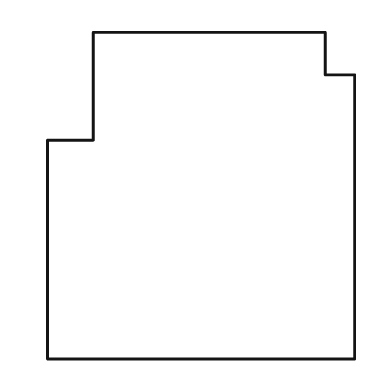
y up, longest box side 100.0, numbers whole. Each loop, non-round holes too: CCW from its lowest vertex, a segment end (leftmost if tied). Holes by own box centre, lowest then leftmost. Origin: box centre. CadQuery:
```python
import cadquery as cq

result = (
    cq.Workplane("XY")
    .moveTo(-47.0, -50.0)
    .lineTo(47.0, -50.0)
    .lineTo(47.0, 37.0)
    .lineTo(38.0, 37.0)
    .lineTo(38.0, 50.0)
    .lineTo(-33.0, 50.0)
    .lineTo(-33.0, 17.0)
    .lineTo(-47.0, 17.0)
    .close()
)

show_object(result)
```